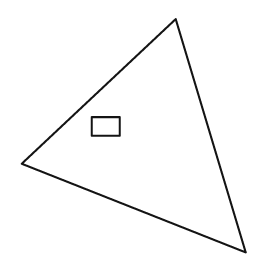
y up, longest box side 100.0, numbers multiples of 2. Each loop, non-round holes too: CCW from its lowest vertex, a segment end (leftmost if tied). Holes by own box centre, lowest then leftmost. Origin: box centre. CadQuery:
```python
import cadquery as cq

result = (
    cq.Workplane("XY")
    .moveTo(48.0, -50.0)
    .lineTo(18.0, 50.0)
    .lineTo(-48.0, -12.0)
    .close()
    .moveTo(-18.0, 0.0)
    .lineTo(-6.0, 0.0)
    .lineTo(-6.0, 8.0)
    .lineTo(-18.0, 8.0)
    .close()
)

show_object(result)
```